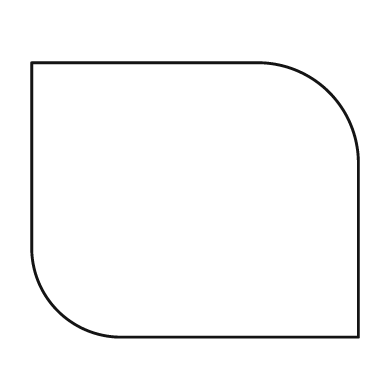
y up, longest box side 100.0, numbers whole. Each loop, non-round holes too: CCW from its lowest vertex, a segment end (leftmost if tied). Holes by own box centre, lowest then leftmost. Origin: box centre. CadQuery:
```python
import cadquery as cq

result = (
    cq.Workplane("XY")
    .moveTo(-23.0, -42.0)
    .lineTo(50.0, -42.0)
    .lineTo(50.0, 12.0)
    .threePointArc((41.0, 33.0), (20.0, 42.0))
    .lineTo(-50.0, 42.0)
    .lineTo(-50.0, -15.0)
    .threePointArc((-42.0, -34.0), (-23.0, -42.0))
    .close()
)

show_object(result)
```